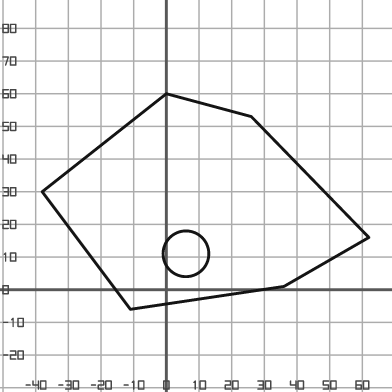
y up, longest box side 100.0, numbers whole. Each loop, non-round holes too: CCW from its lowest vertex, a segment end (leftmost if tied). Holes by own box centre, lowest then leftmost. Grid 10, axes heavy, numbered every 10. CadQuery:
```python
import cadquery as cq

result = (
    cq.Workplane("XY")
    .moveTo(-11.0, -6.0)
    .lineTo(36.0, 1.0)
    .lineTo(62.0, 16.0)
    .lineTo(26.0, 53.0)
    .lineTo(0.0, 60.0)
    .lineTo(-38.0, 30.0)
    .close()
    .moveTo(6.0, 11.0)
    .circle(7.0)
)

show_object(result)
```